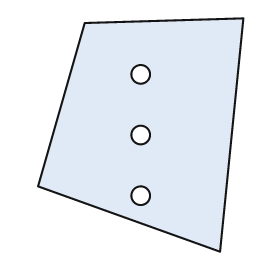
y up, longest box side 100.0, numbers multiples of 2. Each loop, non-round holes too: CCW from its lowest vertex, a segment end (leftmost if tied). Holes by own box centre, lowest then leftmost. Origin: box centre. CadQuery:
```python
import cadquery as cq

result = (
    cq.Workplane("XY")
    .moveTo(34.0, -50.0)
    .lineTo(44.0, 50.0)
    .lineTo(-24.0, 48.0)
    .lineTo(-44.0, -22.0)
    .close()
    .moveTo(0.0, -26.0)
    .circle(4.0)
    .moveTo(0.0, 0.0)
    .circle(4.0)
    .moveTo(0.0, 26.0)
    .circle(4.0)
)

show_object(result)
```